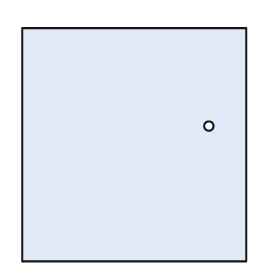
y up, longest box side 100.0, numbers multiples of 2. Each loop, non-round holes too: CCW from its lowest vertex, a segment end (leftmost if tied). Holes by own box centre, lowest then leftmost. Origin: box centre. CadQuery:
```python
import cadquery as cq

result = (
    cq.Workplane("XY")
    .moveTo(-48.0, -50.0)
    .lineTo(48.0, -50.0)
    .lineTo(48.0, 50.0)
    .lineTo(-48.0, 50.0)
    .close()
    .moveTo(32.0, 8.0)
    .circle(2.0)
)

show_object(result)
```